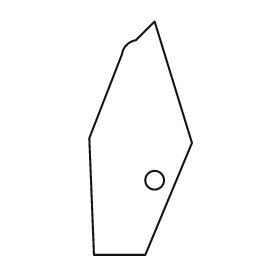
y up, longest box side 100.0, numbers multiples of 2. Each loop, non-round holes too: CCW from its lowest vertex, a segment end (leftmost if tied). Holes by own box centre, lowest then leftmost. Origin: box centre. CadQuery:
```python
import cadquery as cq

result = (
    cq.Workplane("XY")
    .moveTo(-20.0, -50.0)
    .lineTo(2.0, -50.0)
    .lineTo(22.0, -2.0)
    .lineTo(6.0, 50.0)
    .lineTo(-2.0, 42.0)
    .threePointArc((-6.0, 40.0), (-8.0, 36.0))
    .lineTo(-22.0, 0.0)
    .close()
    .moveTo(6.0, -18.0)
    .circle(4.0)
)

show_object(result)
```